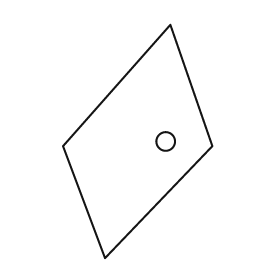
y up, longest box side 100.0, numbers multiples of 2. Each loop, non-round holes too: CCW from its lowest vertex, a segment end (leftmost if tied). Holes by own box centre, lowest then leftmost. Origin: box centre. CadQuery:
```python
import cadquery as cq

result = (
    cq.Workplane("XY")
    .moveTo(-14.0, -50.0)
    .lineTo(32.0, -2.0)
    .lineTo(14.0, 50.0)
    .lineTo(-32.0, -2.0)
    .close()
    .moveTo(12.0, 0.0)
    .circle(4.0)
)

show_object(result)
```